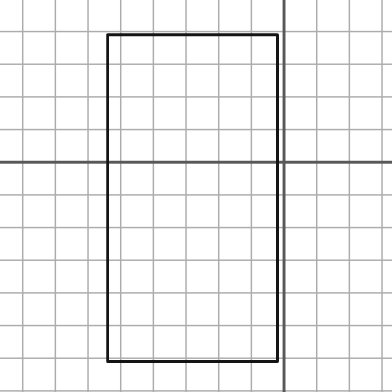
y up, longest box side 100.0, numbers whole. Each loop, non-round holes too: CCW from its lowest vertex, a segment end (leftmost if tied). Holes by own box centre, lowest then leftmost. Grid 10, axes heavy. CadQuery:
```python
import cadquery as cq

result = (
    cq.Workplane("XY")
    .moveTo(-54.0, -61.0)
    .lineTo(-2.0, -61.0)
    .lineTo(-2.0, 39.0)
    .lineTo(-54.0, 39.0)
    .close()
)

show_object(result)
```